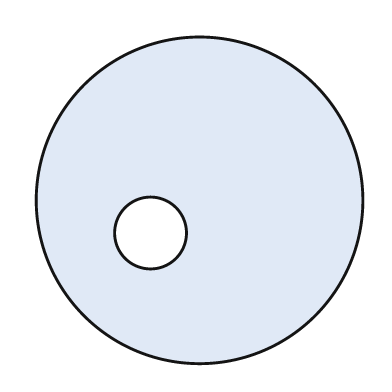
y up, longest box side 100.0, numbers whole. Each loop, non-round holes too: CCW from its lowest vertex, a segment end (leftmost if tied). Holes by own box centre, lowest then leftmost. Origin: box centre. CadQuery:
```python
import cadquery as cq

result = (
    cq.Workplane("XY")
    .moveTo(0.0, 0.0)
    .circle(50.0)
    .moveTo(-15.0, -10.0)
    .circle(11.0)
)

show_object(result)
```